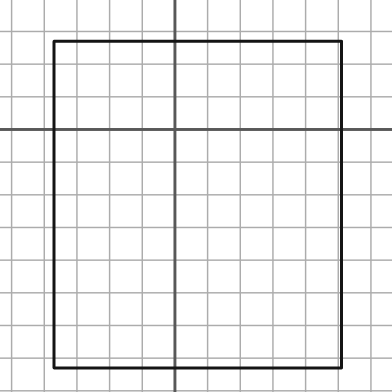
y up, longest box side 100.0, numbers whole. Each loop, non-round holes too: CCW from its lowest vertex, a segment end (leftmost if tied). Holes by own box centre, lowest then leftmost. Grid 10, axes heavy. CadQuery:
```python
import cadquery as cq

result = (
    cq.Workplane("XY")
    .moveTo(-37.0, -73.0)
    .lineTo(51.0, -73.0)
    .lineTo(51.0, 27.0)
    .lineTo(-37.0, 27.0)
    .close()
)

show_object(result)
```